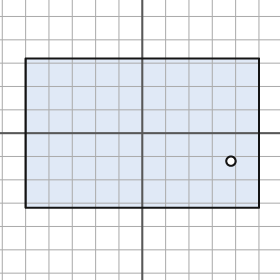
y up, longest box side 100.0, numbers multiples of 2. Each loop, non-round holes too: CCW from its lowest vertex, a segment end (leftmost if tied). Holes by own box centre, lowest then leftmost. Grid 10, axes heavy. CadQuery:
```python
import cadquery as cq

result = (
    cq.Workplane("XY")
    .moveTo(-50.0, -32.0)
    .lineTo(50.0, -32.0)
    .lineTo(50.0, 32.0)
    .lineTo(-50.0, 32.0)
    .close()
    .moveTo(38.0, -12.0)
    .circle(2.0)
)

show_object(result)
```